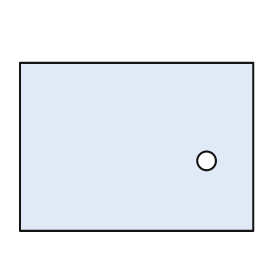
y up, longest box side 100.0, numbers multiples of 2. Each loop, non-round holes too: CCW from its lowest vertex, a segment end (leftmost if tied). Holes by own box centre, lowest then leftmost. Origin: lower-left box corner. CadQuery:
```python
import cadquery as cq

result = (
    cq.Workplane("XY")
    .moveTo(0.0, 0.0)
    .lineTo(100.0, 0.0)
    .lineTo(100.0, 72.0)
    .lineTo(0.0, 72.0)
    .close()
    .moveTo(80.0, 30.0)
    .circle(4.0)
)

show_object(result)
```